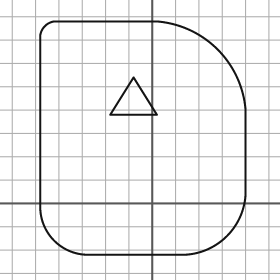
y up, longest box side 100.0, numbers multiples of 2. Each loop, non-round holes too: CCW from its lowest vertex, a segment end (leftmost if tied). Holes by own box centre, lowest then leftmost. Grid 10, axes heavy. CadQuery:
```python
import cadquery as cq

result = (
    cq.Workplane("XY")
    .moveTo(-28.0, -22.0)
    .lineTo(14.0, -22.0)
    .threePointArc((32.0, -14.0), (40.0, 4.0))
    .lineTo(40.0, 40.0)
    .threePointArc((28.0, 66.0), (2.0, 78.0))
    .lineTo(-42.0, 78.0)
    .threePointArc((-46.0, 76.0), (-48.0, 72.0))
    .lineTo(-48.0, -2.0)
    .threePointArc((-42.0, -16.0), (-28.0, -22.0))
    .close()
    .moveTo(-18.0, 38.0)
    .lineTo(2.0, 38.0)
    .lineTo(-8.0, 54.0)
    .close()
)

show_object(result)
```